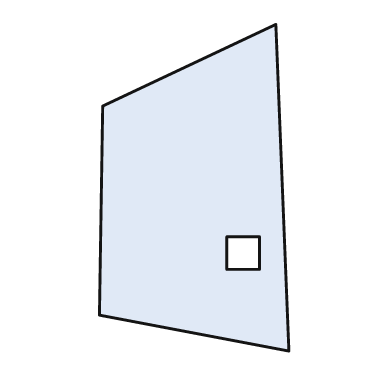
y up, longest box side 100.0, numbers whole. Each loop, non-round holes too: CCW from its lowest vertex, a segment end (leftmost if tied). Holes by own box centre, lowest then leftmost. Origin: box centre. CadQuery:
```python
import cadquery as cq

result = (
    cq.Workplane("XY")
    .moveTo(29.0, -50.0)
    .lineTo(25.0, 50.0)
    .lineTo(-28.0, 25.0)
    .lineTo(-29.0, -39.0)
    .close()
    .moveTo(10.0, -25.0)
    .lineTo(20.0, -25.0)
    .lineTo(20.0, -15.0)
    .lineTo(10.0, -15.0)
    .close()
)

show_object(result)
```